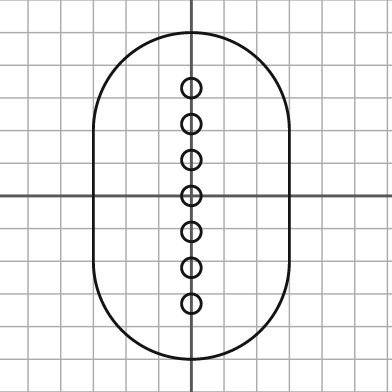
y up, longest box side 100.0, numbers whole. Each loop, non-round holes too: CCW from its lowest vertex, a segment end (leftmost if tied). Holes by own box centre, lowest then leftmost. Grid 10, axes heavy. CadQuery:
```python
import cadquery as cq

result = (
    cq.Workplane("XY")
    .moveTo(-30.0, -20.0)
    .threePointArc((0.0, -50.0), (30.0, -20.0))
    .lineTo(30.0, 20.0)
    .threePointArc((0.0, 50.0), (-30.0, 20.0))
    .close()
    .moveTo(0.0, -33.0)
    .circle(3.0)
    .moveTo(0.0, -22.0)
    .circle(3.0)
    .moveTo(0.0, -11.0)
    .circle(3.0)
    .moveTo(0.0, 0.0)
    .circle(3.0)
    .moveTo(0.0, 11.0)
    .circle(3.0)
    .moveTo(0.0, 22.0)
    .circle(3.0)
    .moveTo(0.0, 33.0)
    .circle(3.0)
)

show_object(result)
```